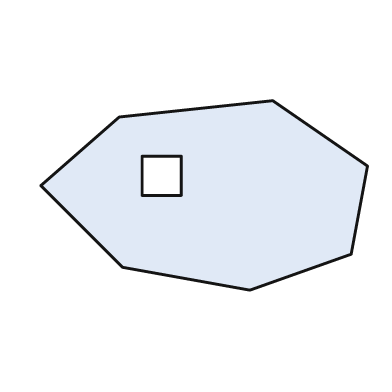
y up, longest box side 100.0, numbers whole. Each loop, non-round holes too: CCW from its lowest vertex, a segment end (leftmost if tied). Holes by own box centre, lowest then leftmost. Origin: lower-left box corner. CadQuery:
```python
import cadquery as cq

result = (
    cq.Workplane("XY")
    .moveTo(64.0, 0.0)
    .lineTo(95.0, 11.0)
    .lineTo(100.0, 38.0)
    .lineTo(71.0, 58.0)
    .lineTo(24.0, 53.0)
    .lineTo(0.0, 32.0)
    .lineTo(25.0, 7.0)
    .close()
    .moveTo(31.0, 29.0)
    .lineTo(43.0, 29.0)
    .lineTo(43.0, 41.0)
    .lineTo(31.0, 41.0)
    .close()
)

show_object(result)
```